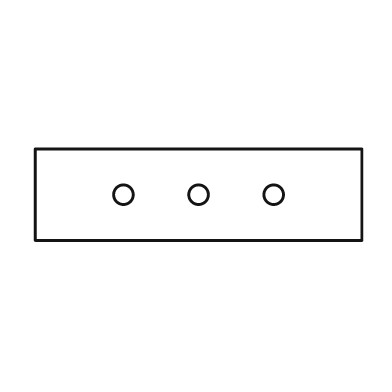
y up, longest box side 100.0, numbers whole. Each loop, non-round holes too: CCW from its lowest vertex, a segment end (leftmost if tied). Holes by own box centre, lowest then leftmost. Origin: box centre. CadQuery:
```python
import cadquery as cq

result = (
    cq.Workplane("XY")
    .moveTo(-50.0, -14.0)
    .lineTo(50.0, -14.0)
    .lineTo(50.0, 14.0)
    .lineTo(-50.0, 14.0)
    .close()
    .moveTo(-23.0, 0.0)
    .circle(3.0)
    .moveTo(0.0, 0.0)
    .circle(3.0)
    .moveTo(23.0, 0.0)
    .circle(3.0)
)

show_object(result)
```